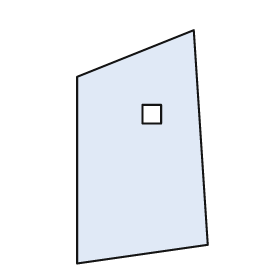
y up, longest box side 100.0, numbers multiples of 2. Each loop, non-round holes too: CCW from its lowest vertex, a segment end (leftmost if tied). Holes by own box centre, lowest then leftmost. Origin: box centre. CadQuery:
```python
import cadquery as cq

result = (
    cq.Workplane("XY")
    .moveTo(-28.0, -50.0)
    .lineTo(28.0, -42.0)
    .lineTo(22.0, 50.0)
    .lineTo(-28.0, 30.0)
    .close()
    .moveTo(0.0, 10.0)
    .lineTo(8.0, 10.0)
    .lineTo(8.0, 18.0)
    .lineTo(0.0, 18.0)
    .close()
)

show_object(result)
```